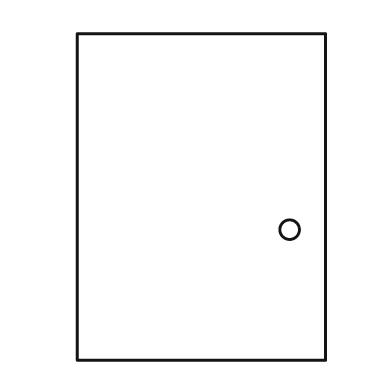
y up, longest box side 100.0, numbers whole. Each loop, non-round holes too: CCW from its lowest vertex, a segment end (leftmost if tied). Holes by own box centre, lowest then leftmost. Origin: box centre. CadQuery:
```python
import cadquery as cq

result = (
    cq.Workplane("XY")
    .moveTo(-38.0, -50.0)
    .lineTo(38.0, -50.0)
    .lineTo(38.0, 50.0)
    .lineTo(-38.0, 50.0)
    .close()
    .moveTo(27.0, -10.0)
    .circle(3.0)
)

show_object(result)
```